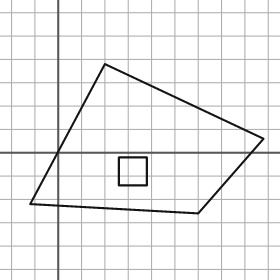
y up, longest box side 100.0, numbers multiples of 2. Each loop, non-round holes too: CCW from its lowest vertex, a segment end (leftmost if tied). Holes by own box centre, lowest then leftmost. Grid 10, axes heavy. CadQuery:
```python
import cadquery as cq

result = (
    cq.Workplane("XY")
    .moveTo(60.0, -26.0)
    .lineTo(88.0, 6.0)
    .lineTo(20.0, 38.0)
    .lineTo(-12.0, -22.0)
    .close()
    .moveTo(26.0, -14.0)
    .lineTo(38.0, -14.0)
    .lineTo(38.0, -2.0)
    .lineTo(26.0, -2.0)
    .close()
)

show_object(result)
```